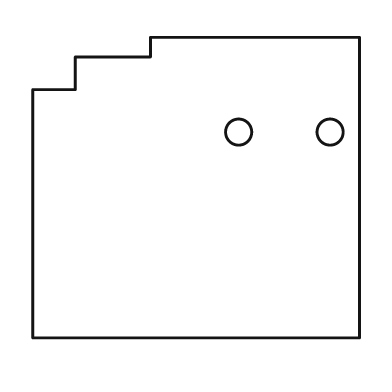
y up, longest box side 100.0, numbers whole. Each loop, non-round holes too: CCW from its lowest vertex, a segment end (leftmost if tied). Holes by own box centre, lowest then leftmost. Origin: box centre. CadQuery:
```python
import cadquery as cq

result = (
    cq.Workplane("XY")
    .moveTo(-50.0, -46.0)
    .lineTo(50.0, -46.0)
    .lineTo(50.0, 46.0)
    .lineTo(-14.0, 46.0)
    .lineTo(-14.0, 40.0)
    .lineTo(-37.0, 40.0)
    .lineTo(-37.0, 30.0)
    .lineTo(-50.0, 30.0)
    .close()
    .moveTo(13.0, 17.0)
    .circle(4.0)
    .moveTo(41.0, 17.0)
    .circle(4.0)
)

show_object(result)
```